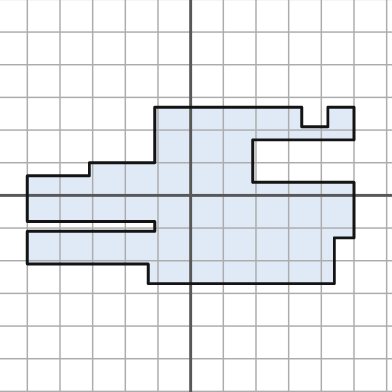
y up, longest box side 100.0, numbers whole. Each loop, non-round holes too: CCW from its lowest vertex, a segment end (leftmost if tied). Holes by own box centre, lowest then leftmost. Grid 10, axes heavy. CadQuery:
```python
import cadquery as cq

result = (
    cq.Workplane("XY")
    .moveTo(-13.0, -27.0)
    .lineTo(44.0, -27.0)
    .lineTo(44.0, -13.0)
    .lineTo(50.0, -13.0)
    .lineTo(50.0, 4.0)
    .lineTo(19.0, 4.0)
    .lineTo(19.0, 17.0)
    .lineTo(50.0, 17.0)
    .lineTo(50.0, 27.0)
    .lineTo(42.0, 27.0)
    .lineTo(42.0, 21.0)
    .lineTo(34.0, 21.0)
    .lineTo(34.0, 27.0)
    .lineTo(-11.0, 27.0)
    .lineTo(-11.0, 10.0)
    .lineTo(-31.0, 10.0)
    .lineTo(-31.0, 6.0)
    .lineTo(-50.0, 6.0)
    .lineTo(-50.0, -8.0)
    .lineTo(-11.0, -8.0)
    .lineTo(-11.0, -11.0)
    .lineTo(-50.0, -11.0)
    .lineTo(-50.0, -21.0)
    .lineTo(-13.0, -21.0)
    .close()
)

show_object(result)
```